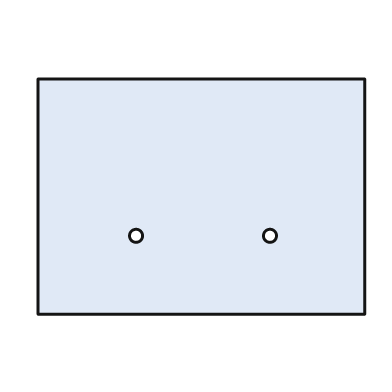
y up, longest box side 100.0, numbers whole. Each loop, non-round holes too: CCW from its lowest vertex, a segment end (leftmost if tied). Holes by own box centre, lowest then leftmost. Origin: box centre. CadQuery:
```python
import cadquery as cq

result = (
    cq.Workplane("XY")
    .moveTo(-50.0, -36.0)
    .lineTo(50.0, -36.0)
    .lineTo(50.0, 36.0)
    .lineTo(-50.0, 36.0)
    .close()
    .moveTo(-20.0, -12.0)
    .circle(2.0)
    .moveTo(21.0, -12.0)
    .circle(2.0)
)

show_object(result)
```